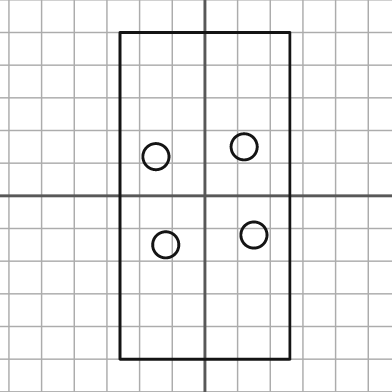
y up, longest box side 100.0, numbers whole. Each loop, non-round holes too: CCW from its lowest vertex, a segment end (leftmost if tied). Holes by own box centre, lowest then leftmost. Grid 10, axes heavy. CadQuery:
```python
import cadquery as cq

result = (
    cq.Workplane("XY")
    .moveTo(-26.0, -50.0)
    .lineTo(26.0, -50.0)
    .lineTo(26.0, 50.0)
    .lineTo(-26.0, 50.0)
    .close()
    .moveTo(-12.0, -15.0)
    .circle(4.0)
    .moveTo(15.0, -12.0)
    .circle(4.0)
    .moveTo(-15.0, 12.0)
    .circle(4.0)
    .moveTo(12.0, 15.0)
    .circle(4.0)
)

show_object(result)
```